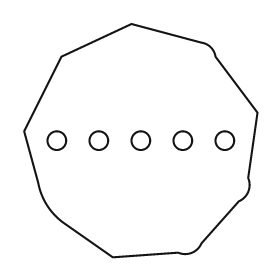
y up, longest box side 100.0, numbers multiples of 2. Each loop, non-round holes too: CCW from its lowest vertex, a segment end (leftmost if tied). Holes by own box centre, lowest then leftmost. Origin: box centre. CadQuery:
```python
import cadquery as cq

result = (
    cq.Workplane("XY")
    .moveTo(-12.0, -50.0)
    .lineTo(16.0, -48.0)
    .threePointArc((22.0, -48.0), (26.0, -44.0))
    .lineTo(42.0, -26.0)
    .threePointArc((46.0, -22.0), (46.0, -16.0))
    .lineTo(50.0, 12.0)
    .lineTo(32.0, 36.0)
    .threePointArc((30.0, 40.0), (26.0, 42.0))
    .lineTo(-4.0, 50.0)
    .lineTo(-34.0, 36.0)
    .lineTo(-50.0, 4.0)
    .lineTo(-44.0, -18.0)
    .threePointArc((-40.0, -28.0), (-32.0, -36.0))
    .close()
    .moveTo(-36.0, 0.0)
    .circle(4.0)
    .moveTo(-18.0, 0.0)
    .circle(4.0)
    .moveTo(0.0, 0.0)
    .circle(4.0)
    .moveTo(18.0, 0.0)
    .circle(4.0)
    .moveTo(36.0, 0.0)
    .circle(4.0)
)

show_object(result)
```